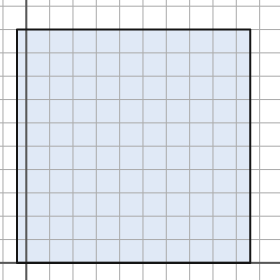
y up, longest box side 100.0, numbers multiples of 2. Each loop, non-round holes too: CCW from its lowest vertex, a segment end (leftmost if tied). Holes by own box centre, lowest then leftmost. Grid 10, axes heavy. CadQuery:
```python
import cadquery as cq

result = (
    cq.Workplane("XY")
    .moveTo(-4.0, 0.0)
    .lineTo(96.0, 0.0)
    .lineTo(96.0, 100.0)
    .lineTo(-4.0, 100.0)
    .close()
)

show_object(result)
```